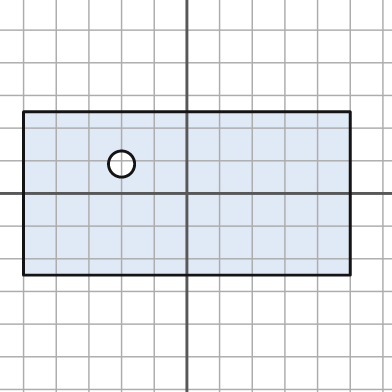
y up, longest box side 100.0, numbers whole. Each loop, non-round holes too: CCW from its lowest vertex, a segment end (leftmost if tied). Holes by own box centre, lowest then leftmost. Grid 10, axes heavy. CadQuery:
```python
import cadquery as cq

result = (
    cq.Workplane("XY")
    .moveTo(-50.0, -25.0)
    .lineTo(50.0, -25.0)
    .lineTo(50.0, 25.0)
    .lineTo(-50.0, 25.0)
    .close()
    .moveTo(-20.0, 9.0)
    .circle(4.0)
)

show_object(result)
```